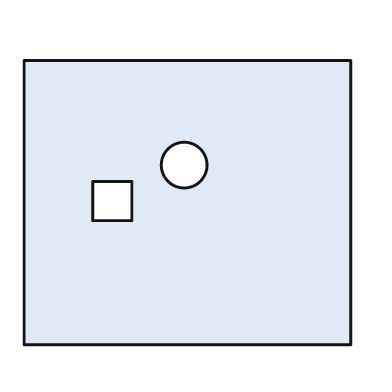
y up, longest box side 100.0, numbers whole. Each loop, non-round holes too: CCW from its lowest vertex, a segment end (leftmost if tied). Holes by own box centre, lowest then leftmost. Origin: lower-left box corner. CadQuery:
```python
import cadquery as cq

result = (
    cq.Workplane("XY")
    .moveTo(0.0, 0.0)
    .lineTo(100.0, 0.0)
    .lineTo(100.0, 87.0)
    .lineTo(0.0, 87.0)
    .close()
    .moveTo(21.0, 38.0)
    .lineTo(33.0, 38.0)
    .lineTo(33.0, 50.0)
    .lineTo(21.0, 50.0)
    .close()
    .moveTo(49.0, 55.0)
    .circle(7.0)
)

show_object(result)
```